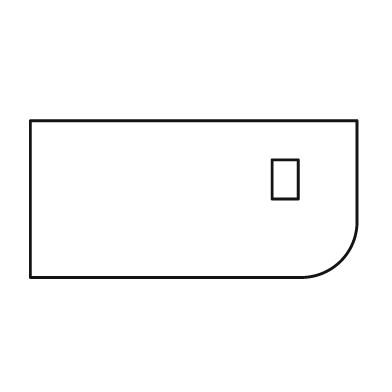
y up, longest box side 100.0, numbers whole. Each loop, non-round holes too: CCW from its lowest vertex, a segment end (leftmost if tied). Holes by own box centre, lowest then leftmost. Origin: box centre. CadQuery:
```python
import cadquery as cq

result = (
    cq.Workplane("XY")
    .moveTo(-50.0, -24.0)
    .lineTo(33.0, -24.0)
    .threePointArc((45.0, -19.0), (50.0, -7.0))
    .lineTo(50.0, 24.0)
    .lineTo(-50.0, 24.0)
    .close()
    .moveTo(24.0, 0.0)
    .lineTo(32.0, 0.0)
    .lineTo(32.0, 12.0)
    .lineTo(24.0, 12.0)
    .close()
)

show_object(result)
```